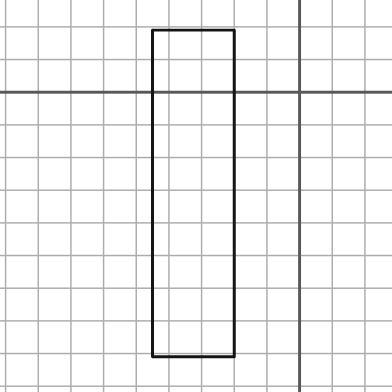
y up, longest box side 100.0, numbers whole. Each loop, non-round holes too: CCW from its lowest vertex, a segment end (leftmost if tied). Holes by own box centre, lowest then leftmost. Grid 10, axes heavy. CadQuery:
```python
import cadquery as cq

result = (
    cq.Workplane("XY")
    .moveTo(-45.0, -81.0)
    .lineTo(-20.0, -81.0)
    .lineTo(-20.0, 19.0)
    .lineTo(-45.0, 19.0)
    .close()
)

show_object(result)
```